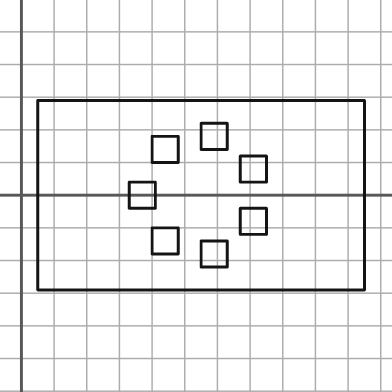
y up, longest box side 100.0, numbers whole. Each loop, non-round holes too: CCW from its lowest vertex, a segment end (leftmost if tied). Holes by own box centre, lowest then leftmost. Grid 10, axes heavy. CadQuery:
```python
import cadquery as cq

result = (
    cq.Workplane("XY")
    .moveTo(5.0, -29.0)
    .lineTo(105.0, -29.0)
    .lineTo(105.0, 29.0)
    .lineTo(5.0, 29.0)
    .close()
    .moveTo(55.0, -22.0)
    .lineTo(63.0, -22.0)
    .lineTo(63.0, -14.0)
    .lineTo(55.0, -14.0)
    .close()
    .moveTo(40.0, -18.0)
    .lineTo(48.0, -18.0)
    .lineTo(48.0, -10.0)
    .lineTo(40.0, -10.0)
    .close()
    .moveTo(67.0, -12.0)
    .lineTo(75.0, -12.0)
    .lineTo(75.0, -4.0)
    .lineTo(67.0, -4.0)
    .close()
    .moveTo(33.0, -4.0)
    .lineTo(41.0, -4.0)
    .lineTo(41.0, 4.0)
    .lineTo(33.0, 4.0)
    .close()
    .moveTo(67.0, 4.0)
    .lineTo(75.0, 4.0)
    .lineTo(75.0, 12.0)
    .lineTo(67.0, 12.0)
    .close()
    .moveTo(40.0, 10.0)
    .lineTo(48.0, 10.0)
    .lineTo(48.0, 18.0)
    .lineTo(40.0, 18.0)
    .close()
    .moveTo(55.0, 14.0)
    .lineTo(63.0, 14.0)
    .lineTo(63.0, 22.0)
    .lineTo(55.0, 22.0)
    .close()
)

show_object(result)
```